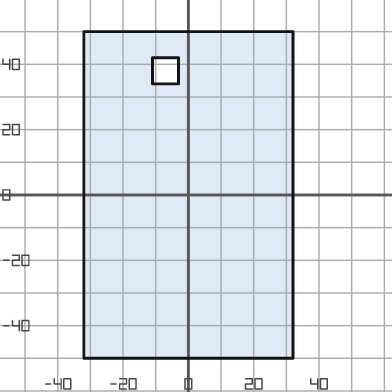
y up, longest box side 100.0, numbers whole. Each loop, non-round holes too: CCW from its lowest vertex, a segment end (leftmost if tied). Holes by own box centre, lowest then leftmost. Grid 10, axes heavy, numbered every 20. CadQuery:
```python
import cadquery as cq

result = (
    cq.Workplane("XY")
    .moveTo(-32.0, -50.0)
    .lineTo(32.0, -50.0)
    .lineTo(32.0, 50.0)
    .lineTo(-32.0, 50.0)
    .close()
    .moveTo(-11.0, 34.0)
    .lineTo(-3.0, 34.0)
    .lineTo(-3.0, 42.0)
    .lineTo(-11.0, 42.0)
    .close()
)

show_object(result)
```